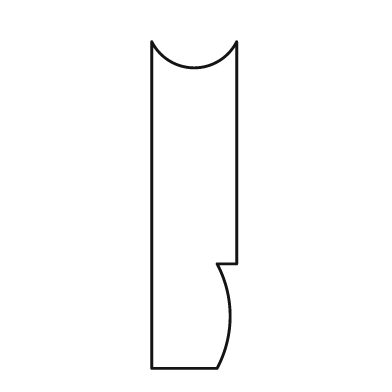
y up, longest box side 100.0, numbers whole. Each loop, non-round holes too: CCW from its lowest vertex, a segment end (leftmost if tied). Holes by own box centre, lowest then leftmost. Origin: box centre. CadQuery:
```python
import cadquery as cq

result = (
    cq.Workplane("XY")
    .moveTo(-13.0, -50.0)
    .lineTo(7.0, -50.0)
    .threePointArc((11.0, -34.0), (7.0, -18.0))
    .lineTo(13.0, -18.0)
    .lineTo(13.0, 50.0)
    .threePointArc((0.0, 42.0), (-13.0, 50.0))
    .close()
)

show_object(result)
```